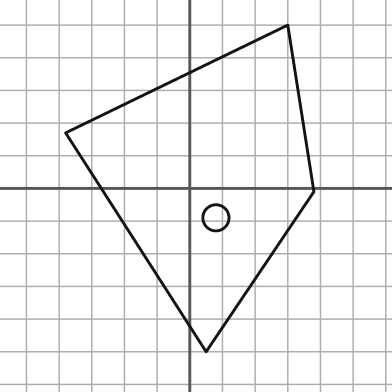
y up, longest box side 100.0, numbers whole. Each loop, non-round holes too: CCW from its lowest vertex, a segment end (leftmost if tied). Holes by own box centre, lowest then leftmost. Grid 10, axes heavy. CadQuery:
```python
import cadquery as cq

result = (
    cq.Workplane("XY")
    .moveTo(5.0, -50.0)
    .lineTo(38.0, -1.0)
    .lineTo(30.0, 50.0)
    .lineTo(-38.0, 17.0)
    .close()
    .moveTo(8.0, -9.0)
    .circle(4.0)
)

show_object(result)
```